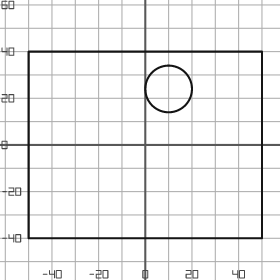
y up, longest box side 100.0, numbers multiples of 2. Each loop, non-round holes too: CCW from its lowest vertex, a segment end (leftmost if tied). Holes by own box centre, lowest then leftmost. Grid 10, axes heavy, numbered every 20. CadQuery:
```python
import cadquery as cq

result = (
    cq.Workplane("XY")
    .moveTo(-50.0, -40.0)
    .lineTo(50.0, -40.0)
    .lineTo(50.0, 40.0)
    .lineTo(-50.0, 40.0)
    .close()
    .moveTo(10.0, 24.0)
    .circle(10.0)
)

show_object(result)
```